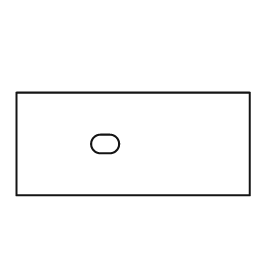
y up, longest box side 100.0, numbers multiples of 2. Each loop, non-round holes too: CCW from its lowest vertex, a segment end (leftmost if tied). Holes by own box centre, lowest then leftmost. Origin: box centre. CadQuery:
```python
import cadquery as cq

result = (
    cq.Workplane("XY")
    .moveTo(-50.0, -22.0)
    .lineTo(50.0, -22.0)
    .lineTo(50.0, 22.0)
    .lineTo(-50.0, 22.0)
    .close()
    .moveTo(-14.0, -4.0)
    .lineTo(-10.0, -4.0)
    .threePointArc((-6.0, 0.0), (-10.0, 4.0))
    .lineTo(-14.0, 4.0)
    .threePointArc((-18.0, 0.0), (-14.0, -4.0))
    .close()
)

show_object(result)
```